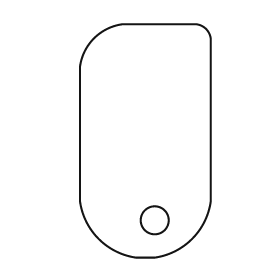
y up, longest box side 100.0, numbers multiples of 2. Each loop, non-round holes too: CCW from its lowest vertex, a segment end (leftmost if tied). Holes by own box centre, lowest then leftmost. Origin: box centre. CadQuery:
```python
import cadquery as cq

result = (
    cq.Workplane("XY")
    .moveTo(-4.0, -50.0)
    .lineTo(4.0, -50.0)
    .threePointArc((20.0, -42.0), (28.0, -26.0))
    .lineTo(28.0, 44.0)
    .threePointArc((26.0, 48.0), (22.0, 50.0))
    .lineTo(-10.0, 50.0)
    .threePointArc((-22.0, 44.0), (-28.0, 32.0))
    .lineTo(-28.0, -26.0)
    .threePointArc((-20.0, -42.0), (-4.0, -50.0))
    .close()
    .moveTo(4.0, -34.0)
    .circle(6.0)
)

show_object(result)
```